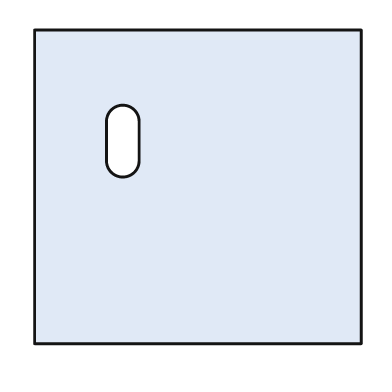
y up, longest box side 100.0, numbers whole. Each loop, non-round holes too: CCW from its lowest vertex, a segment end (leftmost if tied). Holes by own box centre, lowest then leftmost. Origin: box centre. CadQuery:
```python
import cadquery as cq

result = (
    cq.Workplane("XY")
    .moveTo(-50.0, -48.0)
    .lineTo(50.0, -48.0)
    .lineTo(50.0, 48.0)
    .lineTo(-50.0, 48.0)
    .close()
    .moveTo(-28.0, 8.0)
    .threePointArc((-23.0, 3.0), (-18.0, 8.0))
    .lineTo(-18.0, 20.0)
    .threePointArc((-23.0, 25.0), (-28.0, 20.0))
    .close()
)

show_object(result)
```